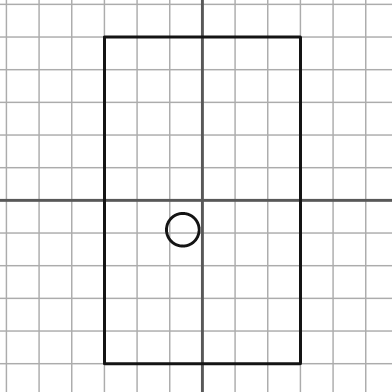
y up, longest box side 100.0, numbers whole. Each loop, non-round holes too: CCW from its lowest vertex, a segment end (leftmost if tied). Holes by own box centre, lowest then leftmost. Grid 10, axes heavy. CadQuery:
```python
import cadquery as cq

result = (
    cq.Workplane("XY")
    .moveTo(-30.0, -50.0)
    .lineTo(30.0, -50.0)
    .lineTo(30.0, 50.0)
    .lineTo(-30.0, 50.0)
    .close()
    .moveTo(-6.0, -9.0)
    .circle(5.0)
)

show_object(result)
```